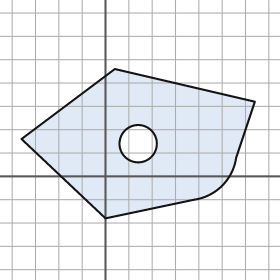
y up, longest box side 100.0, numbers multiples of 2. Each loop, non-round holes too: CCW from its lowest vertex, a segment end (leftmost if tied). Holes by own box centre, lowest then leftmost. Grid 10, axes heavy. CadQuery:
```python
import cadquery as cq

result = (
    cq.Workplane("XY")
    .moveTo(0.0, -18.0)
    .lineTo(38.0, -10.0)
    .threePointArc((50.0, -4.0), (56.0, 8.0))
    .lineTo(64.0, 32.0)
    .lineTo(4.0, 46.0)
    .lineTo(-36.0, 16.0)
    .close()
    .moveTo(14.0, 14.0)
    .circle(8.0)
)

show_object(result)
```